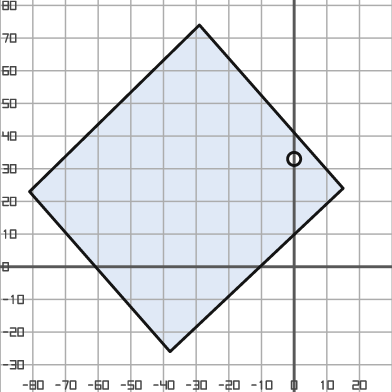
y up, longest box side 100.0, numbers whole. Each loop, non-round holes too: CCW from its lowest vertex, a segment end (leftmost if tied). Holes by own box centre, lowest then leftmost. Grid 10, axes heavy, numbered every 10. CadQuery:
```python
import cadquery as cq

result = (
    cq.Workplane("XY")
    .moveTo(-38.0, -26.0)
    .lineTo(15.0, 24.0)
    .lineTo(-29.0, 74.0)
    .lineTo(-81.0, 23.0)
    .close()
    .moveTo(0.0, 33.0)
    .circle(2.0)
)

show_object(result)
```